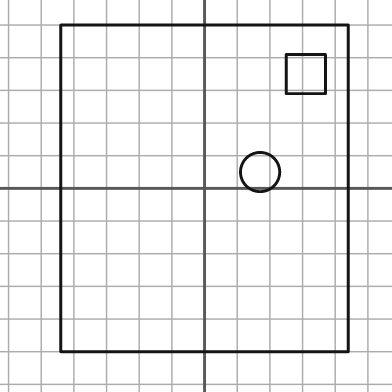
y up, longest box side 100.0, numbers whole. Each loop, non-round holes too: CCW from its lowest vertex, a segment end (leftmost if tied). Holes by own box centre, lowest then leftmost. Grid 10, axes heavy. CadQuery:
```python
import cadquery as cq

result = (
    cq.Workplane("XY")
    .moveTo(-44.0, -50.0)
    .lineTo(44.0, -50.0)
    .lineTo(44.0, 50.0)
    .lineTo(-44.0, 50.0)
    .close()
    .moveTo(17.0, 5.0)
    .circle(6.0)
    .moveTo(25.0, 29.0)
    .lineTo(37.0, 29.0)
    .lineTo(37.0, 41.0)
    .lineTo(25.0, 41.0)
    .close()
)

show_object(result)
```